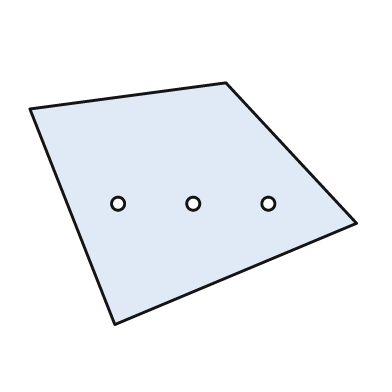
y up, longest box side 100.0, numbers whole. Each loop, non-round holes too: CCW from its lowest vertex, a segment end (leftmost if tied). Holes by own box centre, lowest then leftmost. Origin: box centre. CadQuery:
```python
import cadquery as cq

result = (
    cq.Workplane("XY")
    .moveTo(-24.0, -37.0)
    .lineTo(50.0, -6.0)
    .lineTo(10.0, 37.0)
    .lineTo(-50.0, 29.0)
    .close()
    .moveTo(-23.0, 0.0)
    .circle(2.0)
    .moveTo(0.0, 0.0)
    .circle(2.0)
    .moveTo(23.0, 0.0)
    .circle(2.0)
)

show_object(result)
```